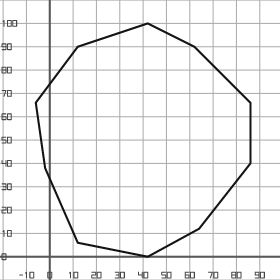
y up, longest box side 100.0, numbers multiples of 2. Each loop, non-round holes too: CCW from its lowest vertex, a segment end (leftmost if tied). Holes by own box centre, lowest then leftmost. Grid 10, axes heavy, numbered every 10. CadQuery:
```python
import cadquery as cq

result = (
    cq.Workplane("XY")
    .moveTo(42.0, 0.0)
    .lineTo(64.0, 12.0)
    .lineTo(86.0, 40.0)
    .lineTo(86.0, 66.0)
    .lineTo(62.0, 90.0)
    .lineTo(42.0, 100.0)
    .lineTo(12.0, 90.0)
    .lineTo(-6.0, 66.0)
    .lineTo(-2.0, 38.0)
    .lineTo(12.0, 6.0)
    .close()
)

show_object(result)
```